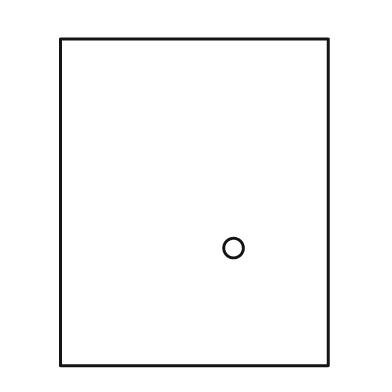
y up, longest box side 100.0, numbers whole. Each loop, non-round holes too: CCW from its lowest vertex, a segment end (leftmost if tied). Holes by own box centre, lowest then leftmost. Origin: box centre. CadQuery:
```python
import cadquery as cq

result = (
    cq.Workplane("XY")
    .moveTo(-41.0, -50.0)
    .lineTo(41.0, -50.0)
    .lineTo(41.0, 50.0)
    .lineTo(-41.0, 50.0)
    .close()
    .moveTo(12.0, -14.0)
    .circle(3.0)
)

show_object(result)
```